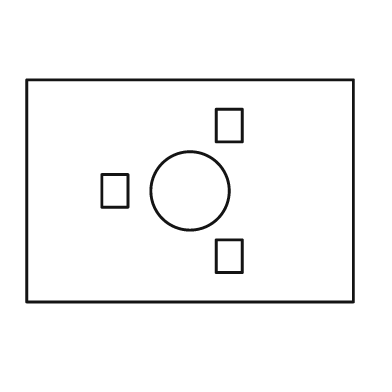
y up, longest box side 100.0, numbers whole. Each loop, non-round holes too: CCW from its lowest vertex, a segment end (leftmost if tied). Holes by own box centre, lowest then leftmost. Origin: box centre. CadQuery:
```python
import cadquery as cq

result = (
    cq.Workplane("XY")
    .moveTo(-50.0, -34.0)
    .lineTo(50.0, -34.0)
    .lineTo(50.0, 34.0)
    .lineTo(-50.0, 34.0)
    .close()
    .moveTo(8.0, -25.0)
    .lineTo(16.0, -25.0)
    .lineTo(16.0, -15.0)
    .lineTo(8.0, -15.0)
    .close()
    .moveTo(-27.0, -5.0)
    .lineTo(-19.0, -5.0)
    .lineTo(-19.0, 5.0)
    .lineTo(-27.0, 5.0)
    .close()
    .moveTo(0.0, 0.0)
    .circle(12.0)
    .moveTo(8.0, 15.0)
    .lineTo(16.0, 15.0)
    .lineTo(16.0, 25.0)
    .lineTo(8.0, 25.0)
    .close()
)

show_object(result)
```